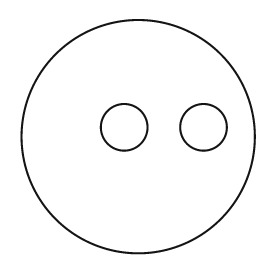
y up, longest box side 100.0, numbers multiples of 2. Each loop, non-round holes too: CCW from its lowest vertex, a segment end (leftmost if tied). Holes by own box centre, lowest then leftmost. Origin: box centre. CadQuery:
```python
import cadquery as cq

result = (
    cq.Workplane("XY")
    .moveTo(0.0, 0.0)
    .circle(50.0)
    .moveTo(-6.0, 4.0)
    .circle(10.0)
    .moveTo(28.0, 4.0)
    .circle(10.0)
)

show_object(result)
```